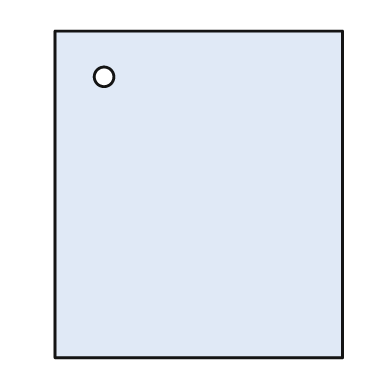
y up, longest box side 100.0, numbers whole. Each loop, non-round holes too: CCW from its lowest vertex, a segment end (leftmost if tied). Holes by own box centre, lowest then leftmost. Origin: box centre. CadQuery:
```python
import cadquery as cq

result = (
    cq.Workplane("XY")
    .moveTo(-44.0, -50.0)
    .lineTo(44.0, -50.0)
    .lineTo(44.0, 50.0)
    .lineTo(-44.0, 50.0)
    .close()
    .moveTo(-29.0, 36.0)
    .circle(3.0)
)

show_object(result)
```